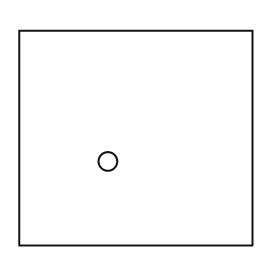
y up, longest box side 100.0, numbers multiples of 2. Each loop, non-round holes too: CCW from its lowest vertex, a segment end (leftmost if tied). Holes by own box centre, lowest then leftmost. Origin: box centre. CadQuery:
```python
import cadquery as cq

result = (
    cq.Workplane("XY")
    .moveTo(-50.0, -46.0)
    .lineTo(50.0, -46.0)
    .lineTo(50.0, 46.0)
    .lineTo(-50.0, 46.0)
    .close()
    .moveTo(-12.0, -10.0)
    .circle(4.0)
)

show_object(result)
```